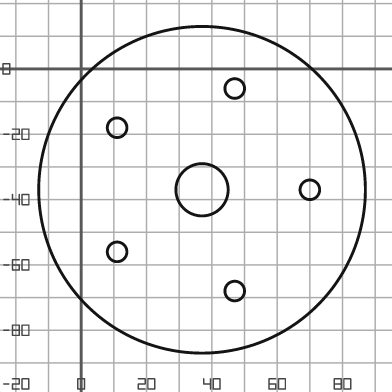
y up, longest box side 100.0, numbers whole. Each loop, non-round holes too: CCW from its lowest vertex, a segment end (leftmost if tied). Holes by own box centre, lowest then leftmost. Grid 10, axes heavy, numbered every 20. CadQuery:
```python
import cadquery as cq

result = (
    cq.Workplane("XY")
    .moveTo(37.0, -37.0)
    .circle(50.0)
    .moveTo(47.0, -68.0)
    .circle(3.0)
    .moveTo(11.0, -56.0)
    .circle(3.0)
    .moveTo(37.0, -37.0)
    .circle(8.0)
    .moveTo(70.0, -37.0)
    .circle(3.0)
    .moveTo(11.0, -18.0)
    .circle(3.0)
    .moveTo(47.0, -6.0)
    .circle(3.0)
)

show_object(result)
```